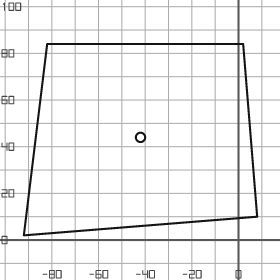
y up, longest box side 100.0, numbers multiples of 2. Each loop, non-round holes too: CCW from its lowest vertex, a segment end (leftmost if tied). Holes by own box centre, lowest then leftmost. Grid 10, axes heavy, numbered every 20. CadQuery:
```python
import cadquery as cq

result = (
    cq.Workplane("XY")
    .moveTo(-92.0, 2.0)
    .lineTo(8.0, 10.0)
    .lineTo(2.0, 84.0)
    .lineTo(-82.0, 84.0)
    .close()
    .moveTo(-42.0, 44.0)
    .circle(2.0)
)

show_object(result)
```